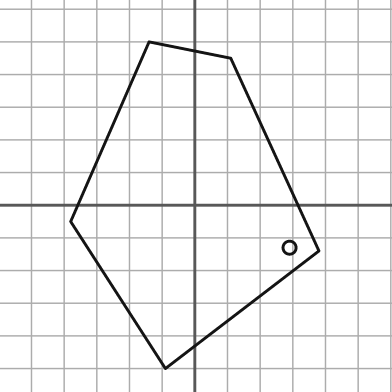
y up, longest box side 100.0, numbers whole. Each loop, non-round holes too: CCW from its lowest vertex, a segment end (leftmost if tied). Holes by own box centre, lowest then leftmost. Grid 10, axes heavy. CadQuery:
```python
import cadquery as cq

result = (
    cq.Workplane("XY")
    .moveTo(-9.0, -50.0)
    .lineTo(38.0, -14.0)
    .lineTo(11.0, 45.0)
    .lineTo(-14.0, 50.0)
    .lineTo(-38.0, -5.0)
    .close()
    .moveTo(29.0, -13.0)
    .circle(2.0)
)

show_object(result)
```